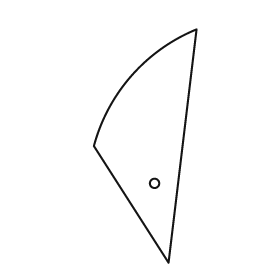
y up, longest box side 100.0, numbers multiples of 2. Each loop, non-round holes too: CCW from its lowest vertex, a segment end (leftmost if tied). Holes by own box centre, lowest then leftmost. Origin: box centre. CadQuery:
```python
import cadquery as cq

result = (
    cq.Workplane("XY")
    .moveTo(10.0, -50.0)
    .lineTo(22.0, 50.0)
    .threePointArc((-6.0, 30.0), (-22.0, 0.0))
    .close()
    .moveTo(4.0, -16.0)
    .circle(2.0)
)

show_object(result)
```